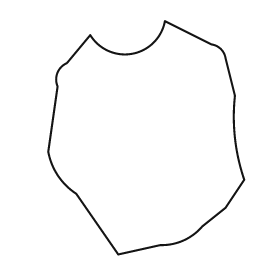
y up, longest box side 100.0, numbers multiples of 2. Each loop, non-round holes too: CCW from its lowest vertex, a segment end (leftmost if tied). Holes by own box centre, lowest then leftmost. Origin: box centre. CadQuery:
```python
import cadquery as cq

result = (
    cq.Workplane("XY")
    .moveTo(-12.0, -50.0)
    .lineTo(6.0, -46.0)
    .threePointArc((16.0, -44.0), (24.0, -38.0))
    .lineTo(34.0, -30.0)
    .lineTo(42.0, -18.0)
    .threePointArc((38.0, 0.0), (38.0, 18.0))
    .lineTo(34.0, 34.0)
    .threePointArc((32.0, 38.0), (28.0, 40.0))
    .lineTo(8.0, 50.0)
    .threePointArc((-6.0, 36.0), (-24.0, 44.0))
    .lineTo(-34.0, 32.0)
    .threePointArc((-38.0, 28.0), (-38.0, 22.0))
    .lineTo(-42.0, -6.0)
    .threePointArc((-38.0, -16.0), (-30.0, -24.0))
    .close()
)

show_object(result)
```